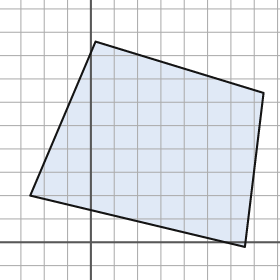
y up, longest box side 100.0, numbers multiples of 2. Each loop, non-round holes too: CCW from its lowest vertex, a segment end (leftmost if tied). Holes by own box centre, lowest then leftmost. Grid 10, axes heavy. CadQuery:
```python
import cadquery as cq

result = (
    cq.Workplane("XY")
    .moveTo(66.0, -2.0)
    .lineTo(74.0, 64.0)
    .lineTo(2.0, 86.0)
    .lineTo(-26.0, 20.0)
    .close()
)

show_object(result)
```